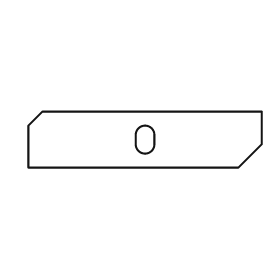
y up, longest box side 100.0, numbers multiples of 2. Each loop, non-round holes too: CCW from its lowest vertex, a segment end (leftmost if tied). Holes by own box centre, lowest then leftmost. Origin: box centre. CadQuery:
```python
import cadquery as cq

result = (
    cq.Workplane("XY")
    .moveTo(-50.0, -12.0)
    .lineTo(40.0, -12.0)
    .lineTo(50.0, -2.0)
    .lineTo(50.0, 12.0)
    .lineTo(-44.0, 12.0)
    .lineTo(-50.0, 6.0)
    .close()
    .moveTo(-4.0, -2.0)
    .threePointArc((0.0, -6.0), (4.0, -2.0))
    .lineTo(4.0, 2.0)
    .threePointArc((0.0, 6.0), (-4.0, 2.0))
    .close()
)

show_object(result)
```